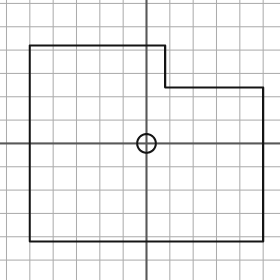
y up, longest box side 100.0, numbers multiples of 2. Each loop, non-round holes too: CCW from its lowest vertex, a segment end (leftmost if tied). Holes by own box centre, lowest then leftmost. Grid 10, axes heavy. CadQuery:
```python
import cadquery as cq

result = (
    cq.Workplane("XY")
    .moveTo(-50.0, -42.0)
    .lineTo(50.0, -42.0)
    .lineTo(50.0, 24.0)
    .lineTo(8.0, 24.0)
    .lineTo(8.0, 42.0)
    .lineTo(-50.0, 42.0)
    .close()
    .moveTo(0.0, 0.0)
    .circle(4.0)
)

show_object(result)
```